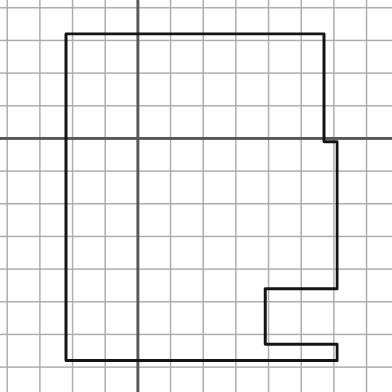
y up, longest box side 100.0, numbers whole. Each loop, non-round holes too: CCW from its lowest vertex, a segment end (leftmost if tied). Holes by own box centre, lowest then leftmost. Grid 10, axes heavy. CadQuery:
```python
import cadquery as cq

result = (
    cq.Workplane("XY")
    .moveTo(-22.0, -68.0)
    .lineTo(61.0, -68.0)
    .lineTo(61.0, -63.0)
    .lineTo(39.0, -63.0)
    .lineTo(39.0, -46.0)
    .lineTo(61.0, -46.0)
    .lineTo(61.0, -1.0)
    .lineTo(57.0, -1.0)
    .lineTo(57.0, 32.0)
    .lineTo(-22.0, 32.0)
    .close()
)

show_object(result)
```